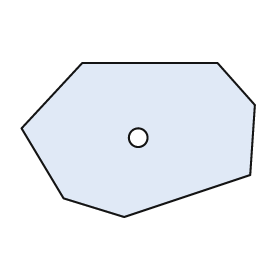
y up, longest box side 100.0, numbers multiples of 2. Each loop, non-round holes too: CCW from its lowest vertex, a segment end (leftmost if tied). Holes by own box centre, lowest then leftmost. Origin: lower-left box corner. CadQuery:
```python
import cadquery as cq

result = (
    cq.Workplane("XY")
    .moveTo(44.0, 0.0)
    .lineTo(98.0, 18.0)
    .lineTo(100.0, 48.0)
    .lineTo(84.0, 66.0)
    .lineTo(26.0, 66.0)
    .lineTo(0.0, 38.0)
    .lineTo(18.0, 8.0)
    .close()
    .moveTo(50.0, 34.0)
    .circle(4.0)
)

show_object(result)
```